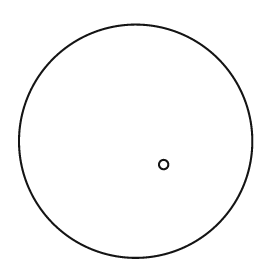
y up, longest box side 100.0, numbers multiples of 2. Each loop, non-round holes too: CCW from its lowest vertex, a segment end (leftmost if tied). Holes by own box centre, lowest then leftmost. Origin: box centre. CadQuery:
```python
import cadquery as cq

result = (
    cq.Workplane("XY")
    .moveTo(0.0, 0.0)
    .circle(50.0)
    .moveTo(12.0, -10.0)
    .circle(2.0)
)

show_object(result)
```